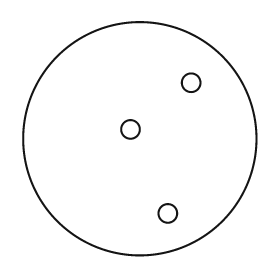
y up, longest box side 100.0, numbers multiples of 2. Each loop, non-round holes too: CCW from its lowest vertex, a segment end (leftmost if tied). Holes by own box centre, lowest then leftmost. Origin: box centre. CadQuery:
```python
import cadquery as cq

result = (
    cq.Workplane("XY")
    .moveTo(0.0, 0.0)
    .circle(50.0)
    .moveTo(12.0, -32.0)
    .circle(4.0)
    .moveTo(-4.0, 4.0)
    .circle(4.0)
    .moveTo(22.0, 24.0)
    .circle(4.0)
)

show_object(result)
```